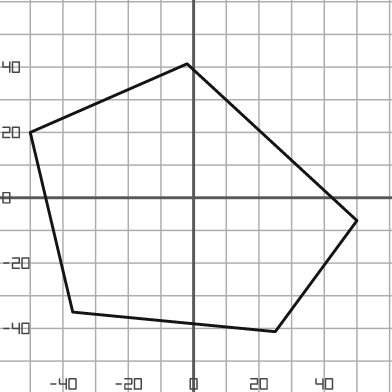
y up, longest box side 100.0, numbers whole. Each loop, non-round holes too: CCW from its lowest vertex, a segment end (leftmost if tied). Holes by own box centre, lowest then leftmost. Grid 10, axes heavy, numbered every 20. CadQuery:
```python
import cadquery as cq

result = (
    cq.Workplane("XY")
    .moveTo(25.0, -41.0)
    .lineTo(50.0, -7.0)
    .lineTo(-2.0, 41.0)
    .lineTo(-50.0, 20.0)
    .lineTo(-37.0, -35.0)
    .close()
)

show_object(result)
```